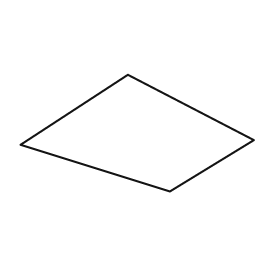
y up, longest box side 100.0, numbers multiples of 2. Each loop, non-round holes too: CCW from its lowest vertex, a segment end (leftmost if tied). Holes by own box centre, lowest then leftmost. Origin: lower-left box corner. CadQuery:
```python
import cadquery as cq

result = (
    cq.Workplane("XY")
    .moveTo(64.0, 0.0)
    .lineTo(100.0, 22.0)
    .lineTo(46.0, 50.0)
    .lineTo(0.0, 20.0)
    .close()
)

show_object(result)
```